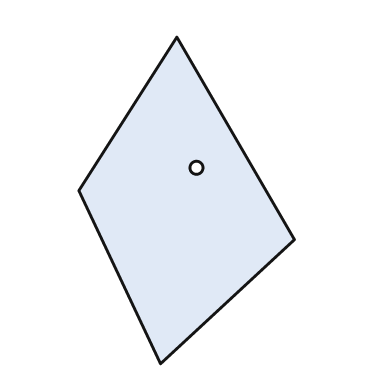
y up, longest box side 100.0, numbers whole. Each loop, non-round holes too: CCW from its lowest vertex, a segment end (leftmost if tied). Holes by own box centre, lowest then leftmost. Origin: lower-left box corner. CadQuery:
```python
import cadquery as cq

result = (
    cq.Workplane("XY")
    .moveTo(25.0, 0.0)
    .lineTo(66.0, 38.0)
    .lineTo(30.0, 100.0)
    .lineTo(0.0, 53.0)
    .close()
    .moveTo(36.0, 60.0)
    .circle(2.0)
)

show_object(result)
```